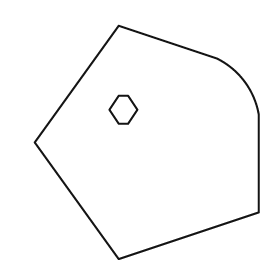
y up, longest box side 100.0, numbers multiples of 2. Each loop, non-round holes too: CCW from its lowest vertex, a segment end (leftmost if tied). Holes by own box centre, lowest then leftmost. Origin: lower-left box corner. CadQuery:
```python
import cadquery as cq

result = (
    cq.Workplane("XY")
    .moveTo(36.0, 0.0)
    .lineTo(96.0, 20.0)
    .lineTo(96.0, 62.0)
    .threePointArc((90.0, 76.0), (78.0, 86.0))
    .lineTo(36.0, 100.0)
    .lineTo(0.0, 50.0)
    .close()
    .moveTo(36.0, 58.0)
    .lineTo(40.0, 58.0)
    .lineTo(44.0, 64.0)
    .lineTo(40.0, 70.0)
    .lineTo(36.0, 70.0)
    .lineTo(32.0, 64.0)
    .close()
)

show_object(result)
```